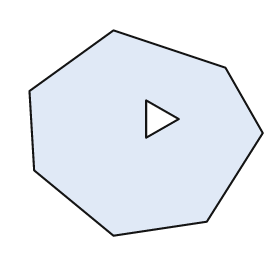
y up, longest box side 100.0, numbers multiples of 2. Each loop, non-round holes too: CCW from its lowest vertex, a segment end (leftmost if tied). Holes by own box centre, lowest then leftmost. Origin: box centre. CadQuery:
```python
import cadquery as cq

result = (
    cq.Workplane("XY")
    .moveTo(-14.0, -44.0)
    .lineTo(26.0, -38.0)
    .lineTo(50.0, 0.0)
    .lineTo(34.0, 28.0)
    .lineTo(-14.0, 44.0)
    .lineTo(-50.0, 18.0)
    .lineTo(-48.0, -16.0)
    .close()
    .moveTo(0.0, -2.0)
    .lineTo(14.0, 6.0)
    .lineTo(0.0, 14.0)
    .close()
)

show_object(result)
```